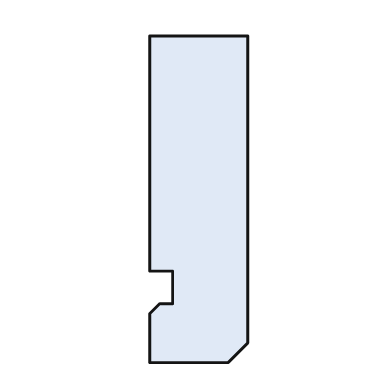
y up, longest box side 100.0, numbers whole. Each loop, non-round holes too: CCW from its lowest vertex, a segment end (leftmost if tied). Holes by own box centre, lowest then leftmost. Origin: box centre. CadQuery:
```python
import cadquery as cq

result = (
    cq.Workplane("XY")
    .moveTo(-15.0, -50.0)
    .lineTo(9.0, -50.0)
    .lineTo(15.0, -44.0)
    .lineTo(15.0, 50.0)
    .lineTo(-15.0, 50.0)
    .lineTo(-15.0, -22.0)
    .lineTo(-8.0, -22.0)
    .lineTo(-8.0, -32.0)
    .lineTo(-12.0, -32.0)
    .lineTo(-15.0, -35.0)
    .close()
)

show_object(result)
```